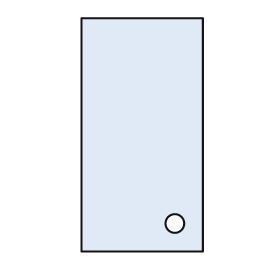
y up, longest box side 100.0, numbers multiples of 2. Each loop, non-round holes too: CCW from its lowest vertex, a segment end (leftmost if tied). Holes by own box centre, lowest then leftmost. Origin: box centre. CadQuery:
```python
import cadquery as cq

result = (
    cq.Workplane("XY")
    .moveTo(-26.0, -50.0)
    .lineTo(26.0, -50.0)
    .lineTo(26.0, 50.0)
    .lineTo(-26.0, 50.0)
    .close()
    .moveTo(14.0, -38.0)
    .circle(4.0)
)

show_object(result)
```